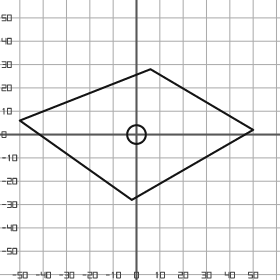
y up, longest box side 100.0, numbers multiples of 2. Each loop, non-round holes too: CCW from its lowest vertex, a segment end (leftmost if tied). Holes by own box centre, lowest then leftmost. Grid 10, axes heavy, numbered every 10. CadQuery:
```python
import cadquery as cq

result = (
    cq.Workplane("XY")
    .moveTo(-2.0, -28.0)
    .lineTo(50.0, 2.0)
    .lineTo(6.0, 28.0)
    .lineTo(-50.0, 6.0)
    .close()
    .moveTo(0.0, 0.0)
    .circle(4.0)
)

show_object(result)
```